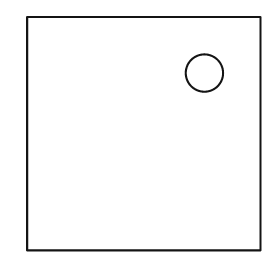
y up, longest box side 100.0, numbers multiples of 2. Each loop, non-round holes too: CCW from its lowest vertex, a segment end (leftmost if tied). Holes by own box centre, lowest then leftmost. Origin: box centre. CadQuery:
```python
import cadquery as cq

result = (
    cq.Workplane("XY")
    .moveTo(-50.0, -50.0)
    .lineTo(50.0, -50.0)
    .lineTo(50.0, 50.0)
    .lineTo(-50.0, 50.0)
    .close()
    .moveTo(26.0, 26.0)
    .circle(8.0)
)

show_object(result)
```